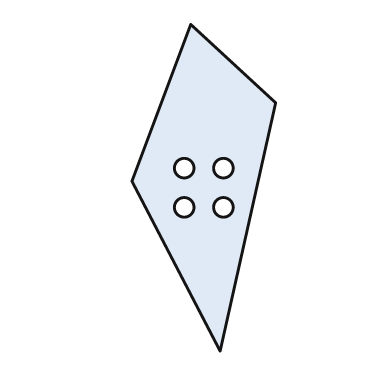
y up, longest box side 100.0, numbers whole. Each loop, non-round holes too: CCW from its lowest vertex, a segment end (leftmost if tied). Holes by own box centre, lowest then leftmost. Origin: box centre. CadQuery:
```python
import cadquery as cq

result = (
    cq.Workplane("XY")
    .moveTo(5.0, -50.0)
    .lineTo(22.0, 26.0)
    .lineTo(-4.0, 50.0)
    .lineTo(-22.0, 2.0)
    .close()
    .moveTo(-6.0, -6.0)
    .circle(3.0)
    .moveTo(6.0, -6.0)
    .circle(3.0)
    .moveTo(-6.0, 6.0)
    .circle(3.0)
    .moveTo(6.0, 6.0)
    .circle(3.0)
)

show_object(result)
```